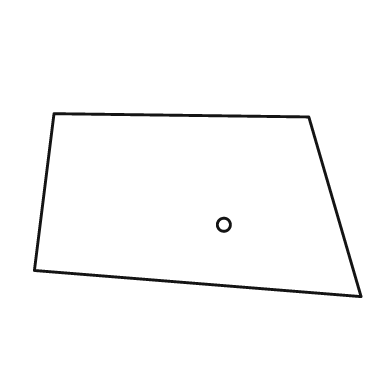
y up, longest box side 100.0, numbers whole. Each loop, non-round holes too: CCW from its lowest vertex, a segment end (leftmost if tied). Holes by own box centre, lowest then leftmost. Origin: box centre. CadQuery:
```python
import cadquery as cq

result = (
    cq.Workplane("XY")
    .moveTo(50.0, -28.0)
    .lineTo(34.0, 27.0)
    .lineTo(-44.0, 28.0)
    .lineTo(-50.0, -20.0)
    .close()
    .moveTo(8.0, -6.0)
    .circle(2.0)
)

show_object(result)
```